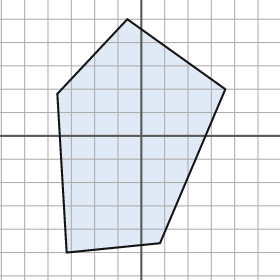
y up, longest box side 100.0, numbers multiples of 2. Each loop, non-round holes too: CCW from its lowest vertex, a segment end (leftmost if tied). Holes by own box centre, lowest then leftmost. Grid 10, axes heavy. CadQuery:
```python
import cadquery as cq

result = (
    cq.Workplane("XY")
    .moveTo(-32.0, -50.0)
    .lineTo(8.0, -46.0)
    .lineTo(36.0, 20.0)
    .lineTo(-6.0, 50.0)
    .lineTo(-36.0, 18.0)
    .close()
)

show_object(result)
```